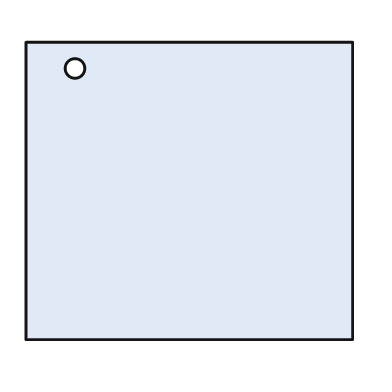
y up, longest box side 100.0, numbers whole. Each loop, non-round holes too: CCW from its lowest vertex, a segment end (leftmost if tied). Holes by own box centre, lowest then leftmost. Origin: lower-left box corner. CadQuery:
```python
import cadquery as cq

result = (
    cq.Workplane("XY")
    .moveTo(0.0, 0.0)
    .lineTo(100.0, 0.0)
    .lineTo(100.0, 91.0)
    .lineTo(0.0, 91.0)
    .close()
    .moveTo(15.0, 83.0)
    .circle(3.0)
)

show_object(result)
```